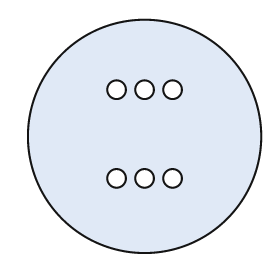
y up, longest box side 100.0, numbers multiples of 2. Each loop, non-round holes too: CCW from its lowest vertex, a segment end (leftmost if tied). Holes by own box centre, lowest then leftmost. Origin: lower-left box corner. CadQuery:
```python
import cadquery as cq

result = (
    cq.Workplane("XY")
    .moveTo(50.0, 50.0)
    .circle(50.0)
    .moveTo(38.0, 32.0)
    .circle(4.0)
    .moveTo(50.0, 32.0)
    .circle(4.0)
    .moveTo(62.0, 32.0)
    .circle(4.0)
    .moveTo(38.0, 70.0)
    .circle(4.0)
    .moveTo(50.0, 70.0)
    .circle(4.0)
    .moveTo(62.0, 70.0)
    .circle(4.0)
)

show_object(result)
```